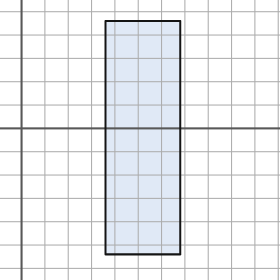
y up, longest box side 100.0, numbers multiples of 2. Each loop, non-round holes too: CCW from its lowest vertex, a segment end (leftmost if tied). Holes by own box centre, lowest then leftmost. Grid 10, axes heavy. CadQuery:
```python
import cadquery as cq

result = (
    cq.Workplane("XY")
    .moveTo(36.0, -54.0)
    .lineTo(68.0, -54.0)
    .lineTo(68.0, 46.0)
    .lineTo(36.0, 46.0)
    .close()
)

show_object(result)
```